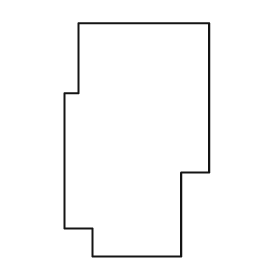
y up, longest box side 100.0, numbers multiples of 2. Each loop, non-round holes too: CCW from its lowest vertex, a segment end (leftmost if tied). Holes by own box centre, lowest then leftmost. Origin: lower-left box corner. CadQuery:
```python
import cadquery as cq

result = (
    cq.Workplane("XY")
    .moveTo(12.0, 0.0)
    .lineTo(50.0, 0.0)
    .lineTo(50.0, 36.0)
    .lineTo(62.0, 36.0)
    .lineTo(62.0, 100.0)
    .lineTo(6.0, 100.0)
    .lineTo(6.0, 70.0)
    .lineTo(0.0, 70.0)
    .lineTo(0.0, 12.0)
    .lineTo(12.0, 12.0)
    .close()
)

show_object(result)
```